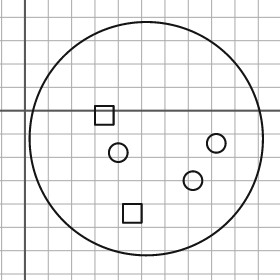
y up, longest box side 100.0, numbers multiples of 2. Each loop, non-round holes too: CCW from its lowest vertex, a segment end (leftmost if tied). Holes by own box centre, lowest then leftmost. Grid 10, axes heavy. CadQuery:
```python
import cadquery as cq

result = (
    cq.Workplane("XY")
    .moveTo(52.0, -12.0)
    .circle(50.0)
    .moveTo(42.0, -48.0)
    .lineTo(50.0, -48.0)
    .lineTo(50.0, -40.0)
    .lineTo(42.0, -40.0)
    .close()
    .moveTo(72.0, -30.0)
    .circle(4.0)
    .moveTo(40.0, -18.0)
    .circle(4.0)
    .moveTo(82.0, -14.0)
    .circle(4.0)
    .moveTo(30.0, -6.0)
    .lineTo(38.0, -6.0)
    .lineTo(38.0, 2.0)
    .lineTo(30.0, 2.0)
    .close()
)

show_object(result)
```